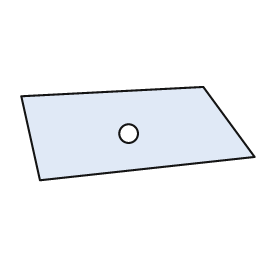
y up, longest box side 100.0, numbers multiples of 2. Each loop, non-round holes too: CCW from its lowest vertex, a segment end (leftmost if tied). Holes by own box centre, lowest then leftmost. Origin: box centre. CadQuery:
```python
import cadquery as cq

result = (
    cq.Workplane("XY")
    .moveTo(-42.0, -20.0)
    .lineTo(50.0, -10.0)
    .lineTo(28.0, 20.0)
    .lineTo(-50.0, 16.0)
    .close()
    .moveTo(-4.0, 0.0)
    .circle(4.0)
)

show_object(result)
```